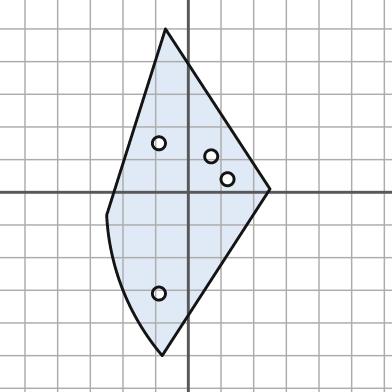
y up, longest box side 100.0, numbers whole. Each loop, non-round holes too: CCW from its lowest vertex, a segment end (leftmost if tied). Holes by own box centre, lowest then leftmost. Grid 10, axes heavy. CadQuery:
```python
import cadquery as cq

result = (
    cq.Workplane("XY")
    .moveTo(-8.0, -50.0)
    .lineTo(25.0, 1.0)
    .lineTo(-7.0, 50.0)
    .lineTo(-25.0, -7.0)
    .threePointArc((-20.0, -30.0), (-8.0, -50.0))
    .close()
    .moveTo(-9.0, -31.0)
    .circle(2.0)
    .moveTo(12.0, 4.0)
    .circle(2.0)
    .moveTo(7.0, 11.0)
    .circle(2.0)
    .moveTo(-9.0, 15.0)
    .circle(2.0)
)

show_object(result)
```